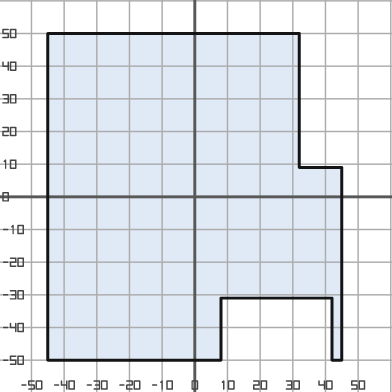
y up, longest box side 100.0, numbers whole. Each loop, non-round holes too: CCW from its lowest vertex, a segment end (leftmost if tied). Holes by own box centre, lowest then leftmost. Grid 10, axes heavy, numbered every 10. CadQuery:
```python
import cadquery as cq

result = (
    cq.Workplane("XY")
    .moveTo(-45.0, -50.0)
    .lineTo(8.0, -50.0)
    .lineTo(8.0, -31.0)
    .lineTo(42.0, -31.0)
    .lineTo(42.0, -50.0)
    .lineTo(45.0, -50.0)
    .lineTo(45.0, 9.0)
    .lineTo(32.0, 9.0)
    .lineTo(32.0, 50.0)
    .lineTo(-45.0, 50.0)
    .close()
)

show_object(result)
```